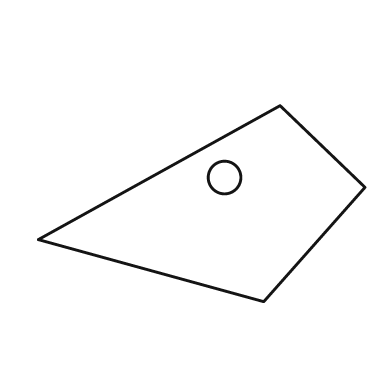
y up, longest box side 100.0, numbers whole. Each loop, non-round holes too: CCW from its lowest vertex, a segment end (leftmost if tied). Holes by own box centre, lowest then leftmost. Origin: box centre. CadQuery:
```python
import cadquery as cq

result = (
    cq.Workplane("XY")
    .moveTo(19.0, -30.0)
    .lineTo(50.0, 5.0)
    .lineTo(24.0, 30.0)
    .lineTo(-50.0, -11.0)
    .close()
    .moveTo(7.0, 8.0)
    .circle(5.0)
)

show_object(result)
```